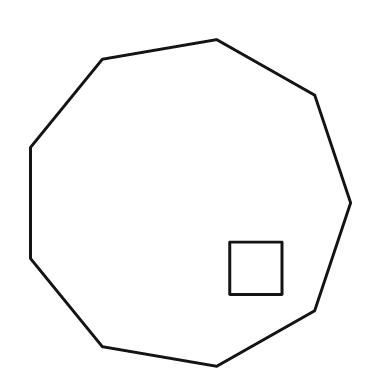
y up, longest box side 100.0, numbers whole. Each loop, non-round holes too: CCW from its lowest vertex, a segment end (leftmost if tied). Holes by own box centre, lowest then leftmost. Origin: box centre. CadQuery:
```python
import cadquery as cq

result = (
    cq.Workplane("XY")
    .moveTo(8.0, -50.0)
    .lineTo(38.0, -33.0)
    .lineTo(49.0, 0.0)
    .lineTo(38.0, 33.0)
    .lineTo(8.0, 50.0)
    .lineTo(-27.0, 44.0)
    .lineTo(-49.0, 17.0)
    .lineTo(-49.0, -17.0)
    .lineTo(-27.0, -44.0)
    .close()
    .moveTo(12.0, -28.0)
    .lineTo(28.0, -28.0)
    .lineTo(28.0, -12.0)
    .lineTo(12.0, -12.0)
    .close()
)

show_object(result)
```